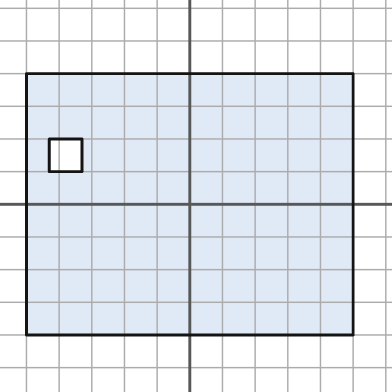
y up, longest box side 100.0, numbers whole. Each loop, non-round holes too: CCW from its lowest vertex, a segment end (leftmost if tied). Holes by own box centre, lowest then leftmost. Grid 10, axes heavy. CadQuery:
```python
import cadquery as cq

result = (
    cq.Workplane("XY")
    .moveTo(-50.0, -40.0)
    .lineTo(50.0, -40.0)
    .lineTo(50.0, 40.0)
    .lineTo(-50.0, 40.0)
    .close()
    .moveTo(-43.0, 10.0)
    .lineTo(-33.0, 10.0)
    .lineTo(-33.0, 20.0)
    .lineTo(-43.0, 20.0)
    .close()
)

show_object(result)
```